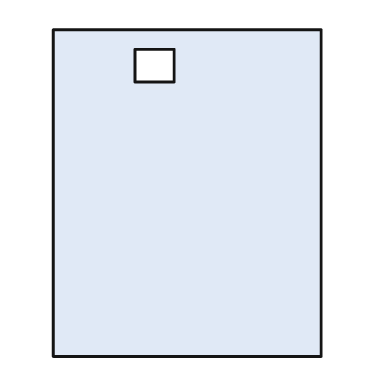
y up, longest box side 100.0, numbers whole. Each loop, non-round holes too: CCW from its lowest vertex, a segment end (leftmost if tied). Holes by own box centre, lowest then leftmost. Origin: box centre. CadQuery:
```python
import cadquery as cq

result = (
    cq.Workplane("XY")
    .moveTo(-41.0, -50.0)
    .lineTo(41.0, -50.0)
    .lineTo(41.0, 50.0)
    .lineTo(-41.0, 50.0)
    .close()
    .moveTo(-16.0, 34.0)
    .lineTo(-4.0, 34.0)
    .lineTo(-4.0, 44.0)
    .lineTo(-16.0, 44.0)
    .close()
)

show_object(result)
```